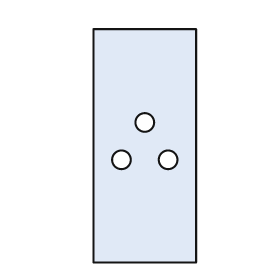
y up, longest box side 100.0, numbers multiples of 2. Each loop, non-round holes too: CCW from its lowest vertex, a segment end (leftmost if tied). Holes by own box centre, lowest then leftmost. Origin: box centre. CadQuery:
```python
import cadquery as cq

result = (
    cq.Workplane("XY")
    .moveTo(-22.0, -50.0)
    .lineTo(22.0, -50.0)
    .lineTo(22.0, 50.0)
    .lineTo(-22.0, 50.0)
    .close()
    .moveTo(-10.0, -6.0)
    .circle(4.0)
    .moveTo(10.0, -6.0)
    .circle(4.0)
    .moveTo(0.0, 10.0)
    .circle(4.0)
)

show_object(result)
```